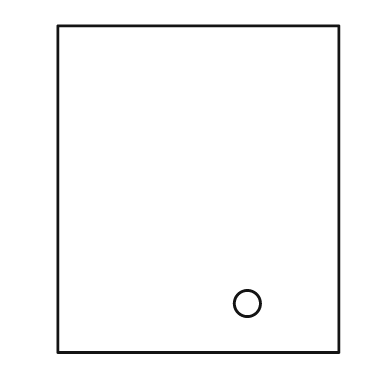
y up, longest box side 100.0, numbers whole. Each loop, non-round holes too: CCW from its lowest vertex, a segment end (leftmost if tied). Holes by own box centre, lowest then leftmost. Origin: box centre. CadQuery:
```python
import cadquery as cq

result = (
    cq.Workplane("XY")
    .moveTo(-43.0, -50.0)
    .lineTo(43.0, -50.0)
    .lineTo(43.0, 50.0)
    .lineTo(-43.0, 50.0)
    .close()
    .moveTo(15.0, -35.0)
    .circle(4.0)
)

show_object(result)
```